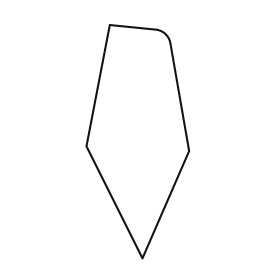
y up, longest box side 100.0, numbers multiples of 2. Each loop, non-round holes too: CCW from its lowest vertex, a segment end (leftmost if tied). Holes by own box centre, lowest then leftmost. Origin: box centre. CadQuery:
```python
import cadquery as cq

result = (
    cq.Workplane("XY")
    .moveTo(2.0, -50.0)
    .lineTo(22.0, -4.0)
    .lineTo(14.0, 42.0)
    .threePointArc((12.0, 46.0), (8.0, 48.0))
    .lineTo(-12.0, 50.0)
    .lineTo(-22.0, -2.0)
    .close()
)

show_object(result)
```